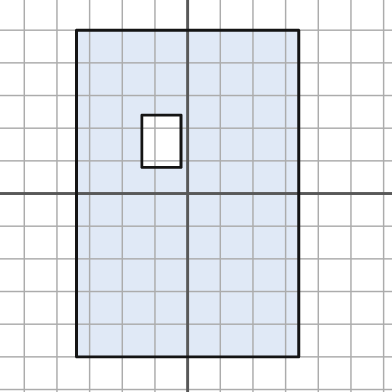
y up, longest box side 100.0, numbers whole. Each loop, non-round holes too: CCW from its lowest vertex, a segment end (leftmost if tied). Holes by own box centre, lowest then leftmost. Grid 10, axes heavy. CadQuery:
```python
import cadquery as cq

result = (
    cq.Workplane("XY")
    .moveTo(-34.0, -50.0)
    .lineTo(34.0, -50.0)
    .lineTo(34.0, 50.0)
    .lineTo(-34.0, 50.0)
    .close()
    .moveTo(-14.0, 8.0)
    .lineTo(-2.0, 8.0)
    .lineTo(-2.0, 24.0)
    .lineTo(-14.0, 24.0)
    .close()
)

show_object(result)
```